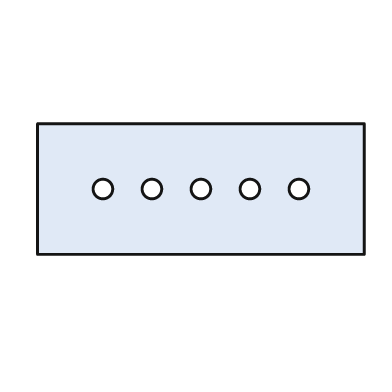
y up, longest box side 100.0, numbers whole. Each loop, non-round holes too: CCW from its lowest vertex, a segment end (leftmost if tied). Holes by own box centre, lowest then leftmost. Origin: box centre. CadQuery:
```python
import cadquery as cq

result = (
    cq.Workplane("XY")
    .moveTo(-50.0, -20.0)
    .lineTo(50.0, -20.0)
    .lineTo(50.0, 20.0)
    .lineTo(-50.0, 20.0)
    .close()
    .moveTo(-30.0, 0.0)
    .circle(3.0)
    .moveTo(-15.0, 0.0)
    .circle(3.0)
    .moveTo(0.0, 0.0)
    .circle(3.0)
    .moveTo(15.0, 0.0)
    .circle(3.0)
    .moveTo(30.0, 0.0)
    .circle(3.0)
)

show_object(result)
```